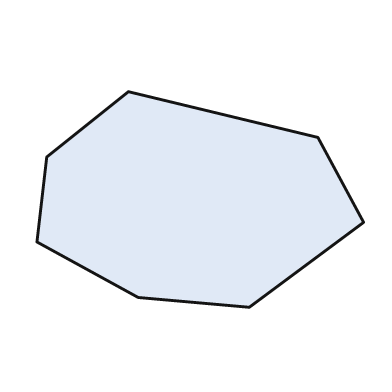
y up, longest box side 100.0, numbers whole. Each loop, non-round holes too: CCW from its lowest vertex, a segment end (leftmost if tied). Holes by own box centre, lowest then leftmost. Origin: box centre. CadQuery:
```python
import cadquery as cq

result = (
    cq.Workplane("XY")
    .moveTo(15.0, -33.0)
    .lineTo(50.0, -7.0)
    .lineTo(36.0, 19.0)
    .lineTo(-22.0, 33.0)
    .lineTo(-47.0, 13.0)
    .lineTo(-50.0, -13.0)
    .lineTo(-19.0, -30.0)
    .close()
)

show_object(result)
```